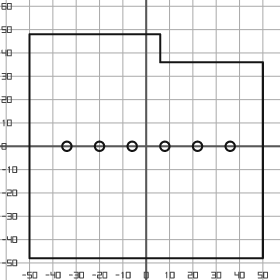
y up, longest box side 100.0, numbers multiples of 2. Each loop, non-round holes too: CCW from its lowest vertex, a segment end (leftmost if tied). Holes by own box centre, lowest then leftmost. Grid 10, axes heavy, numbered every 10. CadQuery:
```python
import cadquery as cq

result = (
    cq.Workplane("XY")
    .moveTo(-50.0, -48.0)
    .lineTo(50.0, -48.0)
    .lineTo(50.0, 36.0)
    .lineTo(6.0, 36.0)
    .lineTo(6.0, 48.0)
    .lineTo(-50.0, 48.0)
    .close()
    .moveTo(-34.0, 0.0)
    .circle(2.0)
    .moveTo(-20.0, 0.0)
    .circle(2.0)
    .moveTo(-6.0, 0.0)
    .circle(2.0)
    .moveTo(8.0, 0.0)
    .circle(2.0)
    .moveTo(22.0, 0.0)
    .circle(2.0)
    .moveTo(36.0, 0.0)
    .circle(2.0)
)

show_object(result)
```